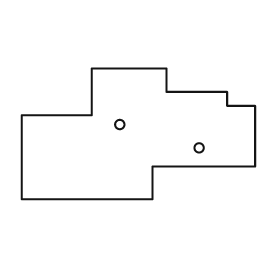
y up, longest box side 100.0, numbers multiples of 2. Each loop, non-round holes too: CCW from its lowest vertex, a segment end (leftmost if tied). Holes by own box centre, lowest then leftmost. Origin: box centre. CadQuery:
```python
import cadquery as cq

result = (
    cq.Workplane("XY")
    .moveTo(-50.0, -28.0)
    .lineTo(6.0, -28.0)
    .lineTo(6.0, -14.0)
    .lineTo(50.0, -14.0)
    .lineTo(50.0, 12.0)
    .lineTo(38.0, 12.0)
    .lineTo(38.0, 18.0)
    .lineTo(12.0, 18.0)
    .lineTo(12.0, 28.0)
    .lineTo(-20.0, 28.0)
    .lineTo(-20.0, 8.0)
    .lineTo(-50.0, 8.0)
    .close()
    .moveTo(26.0, -6.0)
    .circle(2.0)
    .moveTo(-8.0, 4.0)
    .circle(2.0)
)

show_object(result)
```